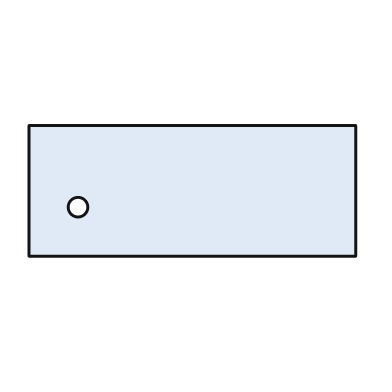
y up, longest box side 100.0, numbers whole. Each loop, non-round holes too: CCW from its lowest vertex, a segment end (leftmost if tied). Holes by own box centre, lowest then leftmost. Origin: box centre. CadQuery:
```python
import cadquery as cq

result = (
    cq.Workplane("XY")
    .moveTo(-50.0, -20.0)
    .lineTo(50.0, -20.0)
    .lineTo(50.0, 20.0)
    .lineTo(-50.0, 20.0)
    .close()
    .moveTo(-35.0, -5.0)
    .circle(3.0)
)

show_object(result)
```